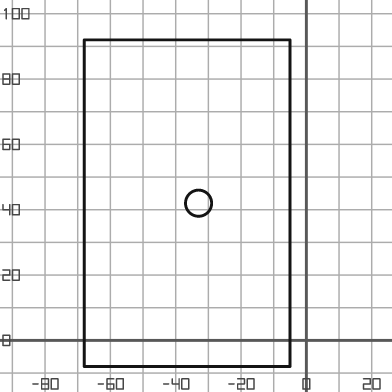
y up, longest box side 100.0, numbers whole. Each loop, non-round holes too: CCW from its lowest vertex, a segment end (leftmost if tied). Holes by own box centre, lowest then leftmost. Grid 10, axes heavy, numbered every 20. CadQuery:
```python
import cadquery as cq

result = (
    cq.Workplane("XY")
    .moveTo(-68.0, -8.0)
    .lineTo(-5.0, -8.0)
    .lineTo(-5.0, 92.0)
    .lineTo(-68.0, 92.0)
    .close()
    .moveTo(-33.0, 42.0)
    .circle(4.0)
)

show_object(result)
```